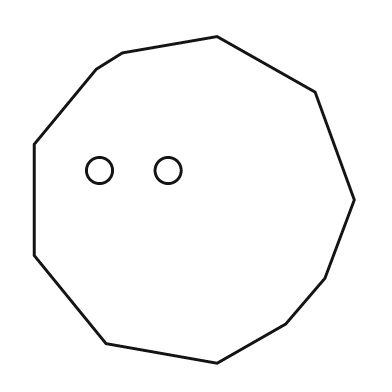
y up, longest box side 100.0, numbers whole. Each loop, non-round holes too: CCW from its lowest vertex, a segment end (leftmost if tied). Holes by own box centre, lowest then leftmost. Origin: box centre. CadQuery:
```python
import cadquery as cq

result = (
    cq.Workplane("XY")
    .moveTo(7.0, -50.0)
    .lineTo(28.0, -38.0)
    .lineTo(40.0, -24.0)
    .lineTo(49.0, 0.0)
    .lineTo(37.0, 33.0)
    .lineTo(7.0, 50.0)
    .lineTo(-22.0, 45.0)
    .lineTo(-30.0, 40.0)
    .lineTo(-49.0, 17.0)
    .lineTo(-49.0, -17.0)
    .lineTo(-27.0, -44.0)
    .close()
    .moveTo(-29.0, 9.0)
    .circle(4.0)
    .moveTo(-8.0, 9.0)
    .circle(4.0)
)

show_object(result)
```